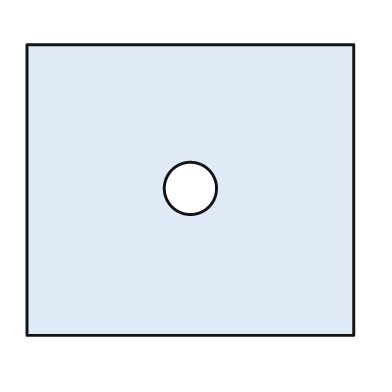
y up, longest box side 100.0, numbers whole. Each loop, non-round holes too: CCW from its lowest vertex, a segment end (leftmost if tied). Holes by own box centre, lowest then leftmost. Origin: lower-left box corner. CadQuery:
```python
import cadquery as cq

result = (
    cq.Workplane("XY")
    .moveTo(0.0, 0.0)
    .lineTo(100.0, 0.0)
    .lineTo(100.0, 89.0)
    .lineTo(0.0, 89.0)
    .close()
    .moveTo(50.0, 45.0)
    .circle(8.0)
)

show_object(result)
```